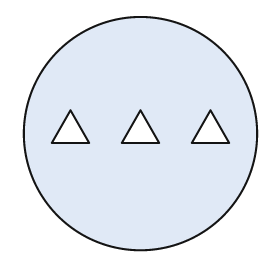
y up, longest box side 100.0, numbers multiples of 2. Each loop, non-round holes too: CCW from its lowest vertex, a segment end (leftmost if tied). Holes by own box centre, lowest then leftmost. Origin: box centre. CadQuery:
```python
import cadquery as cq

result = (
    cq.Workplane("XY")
    .moveTo(0.0, 0.0)
    .circle(50.0)
    .moveTo(-38.0, -4.0)
    .lineTo(-22.0, -4.0)
    .lineTo(-30.0, 10.0)
    .close()
    .moveTo(-8.0, -4.0)
    .lineTo(8.0, -4.0)
    .lineTo(0.0, 10.0)
    .close()
    .moveTo(22.0, -4.0)
    .lineTo(38.0, -4.0)
    .lineTo(30.0, 10.0)
    .close()
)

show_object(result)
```